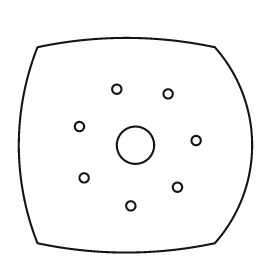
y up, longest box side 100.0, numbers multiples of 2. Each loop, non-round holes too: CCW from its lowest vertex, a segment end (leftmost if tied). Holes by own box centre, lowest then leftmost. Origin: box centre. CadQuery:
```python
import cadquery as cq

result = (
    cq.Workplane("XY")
    .moveTo(-42.0, -42.0)
    .threePointArc((-4.0, -46.0), (34.0, -42.0))
    .threePointArc((50.0, 0.0), (34.0, 42.0))
    .threePointArc((-4.0, 46.0), (-42.0, 42.0))
    .threePointArc((-50.0, 0.0), (-42.0, -42.0))
    .close()
    .moveTo(-2.0, -26.0)
    .circle(2.0)
    .moveTo(18.0, -18.0)
    .circle(2.0)
    .moveTo(-22.0, -14.0)
    .circle(2.0)
    .moveTo(0.0, 0.0)
    .circle(8.0)
    .moveTo(26.0, 2.0)
    .circle(2.0)
    .moveTo(-24.0, 8.0)
    .circle(2.0)
    .moveTo(14.0, 22.0)
    .circle(2.0)
    .moveTo(-8.0, 24.0)
    .circle(2.0)
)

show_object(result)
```